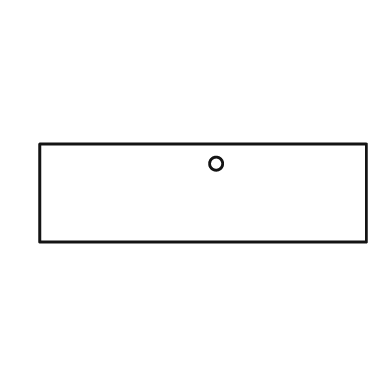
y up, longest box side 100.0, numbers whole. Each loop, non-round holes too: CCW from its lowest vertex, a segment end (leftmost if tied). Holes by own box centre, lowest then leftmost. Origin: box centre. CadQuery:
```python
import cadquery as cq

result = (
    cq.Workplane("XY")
    .moveTo(-50.0, -15.0)
    .lineTo(50.0, -15.0)
    .lineTo(50.0, 15.0)
    .lineTo(-50.0, 15.0)
    .close()
    .moveTo(4.0, 9.0)
    .circle(2.0)
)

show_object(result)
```